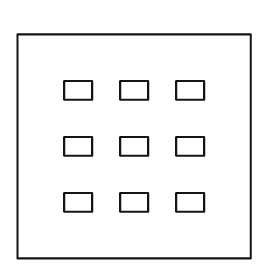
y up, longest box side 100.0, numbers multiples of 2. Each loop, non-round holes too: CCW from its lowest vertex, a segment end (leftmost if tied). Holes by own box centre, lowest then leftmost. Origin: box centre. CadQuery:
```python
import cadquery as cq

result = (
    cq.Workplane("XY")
    .moveTo(-50.0, -48.0)
    .lineTo(50.0, -48.0)
    .lineTo(50.0, 48.0)
    .lineTo(-50.0, 48.0)
    .close()
    .moveTo(-30.0, -28.0)
    .lineTo(-18.0, -28.0)
    .lineTo(-18.0, -20.0)
    .lineTo(-30.0, -20.0)
    .close()
    .moveTo(-6.0, -28.0)
    .lineTo(6.0, -28.0)
    .lineTo(6.0, -20.0)
    .lineTo(-6.0, -20.0)
    .close()
    .moveTo(18.0, -28.0)
    .lineTo(30.0, -28.0)
    .lineTo(30.0, -20.0)
    .lineTo(18.0, -20.0)
    .close()
    .moveTo(-30.0, -4.0)
    .lineTo(-18.0, -4.0)
    .lineTo(-18.0, 4.0)
    .lineTo(-30.0, 4.0)
    .close()
    .moveTo(-6.0, -4.0)
    .lineTo(6.0, -4.0)
    .lineTo(6.0, 4.0)
    .lineTo(-6.0, 4.0)
    .close()
    .moveTo(18.0, -4.0)
    .lineTo(30.0, -4.0)
    .lineTo(30.0, 4.0)
    .lineTo(18.0, 4.0)
    .close()
    .moveTo(-30.0, 20.0)
    .lineTo(-18.0, 20.0)
    .lineTo(-18.0, 28.0)
    .lineTo(-30.0, 28.0)
    .close()
    .moveTo(-6.0, 20.0)
    .lineTo(6.0, 20.0)
    .lineTo(6.0, 28.0)
    .lineTo(-6.0, 28.0)
    .close()
    .moveTo(18.0, 20.0)
    .lineTo(30.0, 20.0)
    .lineTo(30.0, 28.0)
    .lineTo(18.0, 28.0)
    .close()
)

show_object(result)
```